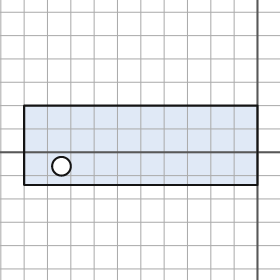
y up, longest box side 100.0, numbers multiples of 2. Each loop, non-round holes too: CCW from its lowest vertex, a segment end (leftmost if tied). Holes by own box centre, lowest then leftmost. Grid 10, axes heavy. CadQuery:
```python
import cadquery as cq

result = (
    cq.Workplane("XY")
    .moveTo(-100.0, -14.0)
    .lineTo(0.0, -14.0)
    .lineTo(0.0, 20.0)
    .lineTo(-100.0, 20.0)
    .close()
    .moveTo(-84.0, -6.0)
    .circle(4.0)
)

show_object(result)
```